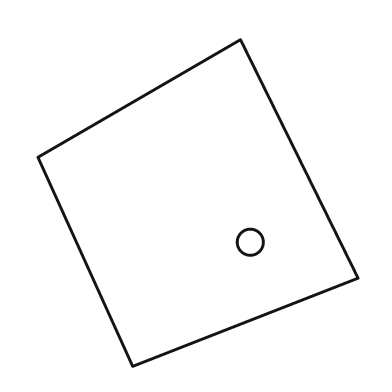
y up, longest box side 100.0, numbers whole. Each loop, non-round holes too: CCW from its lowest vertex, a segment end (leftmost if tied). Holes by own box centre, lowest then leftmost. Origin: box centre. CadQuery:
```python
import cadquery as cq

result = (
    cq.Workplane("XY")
    .moveTo(-20.0, -50.0)
    .lineTo(49.0, -23.0)
    .lineTo(13.0, 50.0)
    .lineTo(-49.0, 14.0)
    .close()
    .moveTo(16.0, -12.0)
    .circle(4.0)
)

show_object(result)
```